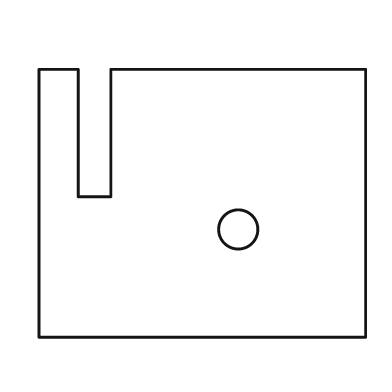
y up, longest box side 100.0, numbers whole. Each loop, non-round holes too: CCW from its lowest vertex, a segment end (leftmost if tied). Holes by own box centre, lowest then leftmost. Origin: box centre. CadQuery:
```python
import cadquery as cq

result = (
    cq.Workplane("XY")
    .moveTo(-50.0, -41.0)
    .lineTo(50.0, -41.0)
    .lineTo(50.0, 41.0)
    .lineTo(-28.0, 41.0)
    .lineTo(-28.0, 2.0)
    .lineTo(-38.0, 2.0)
    .lineTo(-38.0, 41.0)
    .lineTo(-50.0, 41.0)
    .close()
    .moveTo(11.0, -8.0)
    .circle(6.0)
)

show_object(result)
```